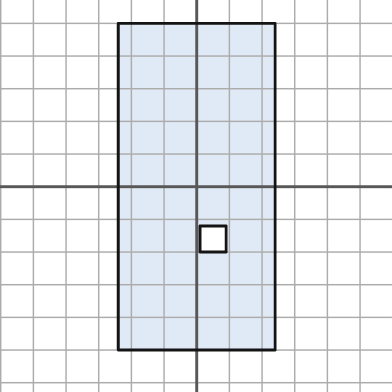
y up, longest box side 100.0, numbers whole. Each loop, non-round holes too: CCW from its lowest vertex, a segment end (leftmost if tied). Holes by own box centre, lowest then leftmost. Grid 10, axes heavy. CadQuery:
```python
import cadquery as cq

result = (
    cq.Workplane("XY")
    .moveTo(-24.0, -50.0)
    .lineTo(24.0, -50.0)
    .lineTo(24.0, 50.0)
    .lineTo(-24.0, 50.0)
    .close()
    .moveTo(1.0, -20.0)
    .lineTo(9.0, -20.0)
    .lineTo(9.0, -12.0)
    .lineTo(1.0, -12.0)
    .close()
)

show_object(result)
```